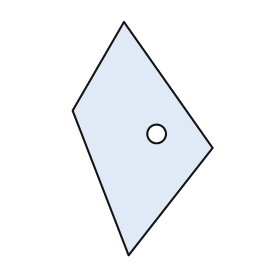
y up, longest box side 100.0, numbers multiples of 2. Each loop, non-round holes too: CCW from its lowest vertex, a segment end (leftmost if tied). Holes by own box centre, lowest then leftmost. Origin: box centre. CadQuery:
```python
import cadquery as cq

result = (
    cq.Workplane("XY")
    .moveTo(-6.0, -50.0)
    .lineTo(30.0, -4.0)
    .lineTo(-8.0, 50.0)
    .lineTo(-30.0, 12.0)
    .close()
    .moveTo(6.0, 2.0)
    .circle(4.0)
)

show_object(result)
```